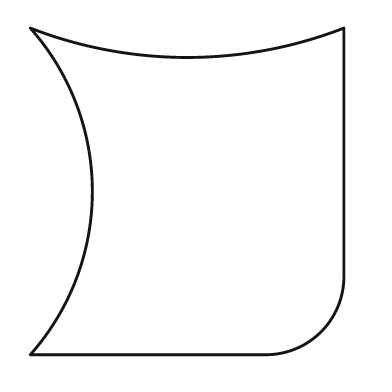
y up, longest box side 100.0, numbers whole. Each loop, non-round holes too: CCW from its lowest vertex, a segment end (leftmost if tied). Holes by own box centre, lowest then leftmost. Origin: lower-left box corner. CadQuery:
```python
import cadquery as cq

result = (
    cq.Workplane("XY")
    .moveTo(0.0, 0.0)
    .lineTo(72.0, 0.0)
    .threePointArc((89.0, 7.0), (96.0, 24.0))
    .lineTo(96.0, 100.0)
    .threePointArc((48.0, 91.0), (0.0, 100.0))
    .threePointArc((19.0, 50.0), (0.0, 0.0))
    .close()
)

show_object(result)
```